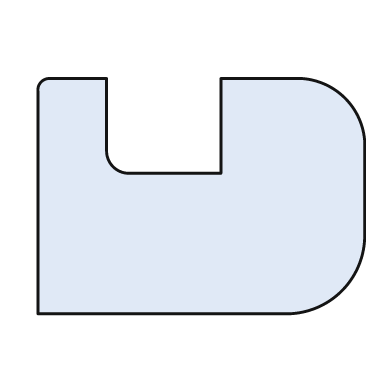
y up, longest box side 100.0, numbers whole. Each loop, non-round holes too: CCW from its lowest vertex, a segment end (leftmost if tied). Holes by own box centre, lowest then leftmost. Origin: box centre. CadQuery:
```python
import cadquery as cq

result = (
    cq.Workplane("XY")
    .moveTo(-50.0, -36.0)
    .lineTo(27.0, -36.0)
    .threePointArc((43.0, -29.0), (50.0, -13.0))
    .lineTo(50.0, 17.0)
    .threePointArc((44.0, 30.0), (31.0, 36.0))
    .lineTo(6.0, 36.0)
    .lineTo(6.0, 7.0)
    .lineTo(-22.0, 7.0)
    .threePointArc((-27.0, 9.0), (-29.0, 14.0))
    .lineTo(-29.0, 36.0)
    .lineTo(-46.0, 36.0)
    .threePointArc((-49.0, 35.0), (-50.0, 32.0))
    .close()
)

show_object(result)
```